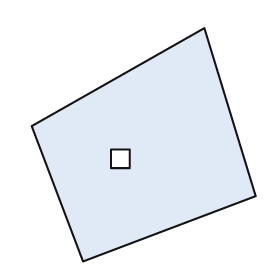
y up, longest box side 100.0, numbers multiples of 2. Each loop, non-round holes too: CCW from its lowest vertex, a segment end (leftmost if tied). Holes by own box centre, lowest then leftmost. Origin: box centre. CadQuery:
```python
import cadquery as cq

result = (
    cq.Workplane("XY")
    .moveTo(-26.0, -50.0)
    .lineTo(48.0, -22.0)
    .lineTo(26.0, 50.0)
    .lineTo(-48.0, 8.0)
    .close()
    .moveTo(-14.0, -10.0)
    .lineTo(-6.0, -10.0)
    .lineTo(-6.0, -2.0)
    .lineTo(-14.0, -2.0)
    .close()
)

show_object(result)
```